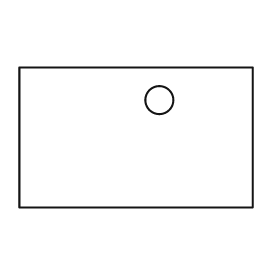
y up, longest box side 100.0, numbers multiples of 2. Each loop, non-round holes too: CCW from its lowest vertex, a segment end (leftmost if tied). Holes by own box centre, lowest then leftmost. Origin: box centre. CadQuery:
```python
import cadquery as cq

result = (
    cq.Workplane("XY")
    .moveTo(-50.0, -30.0)
    .lineTo(50.0, -30.0)
    .lineTo(50.0, 30.0)
    .lineTo(-50.0, 30.0)
    .close()
    .moveTo(10.0, 16.0)
    .circle(6.0)
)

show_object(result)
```